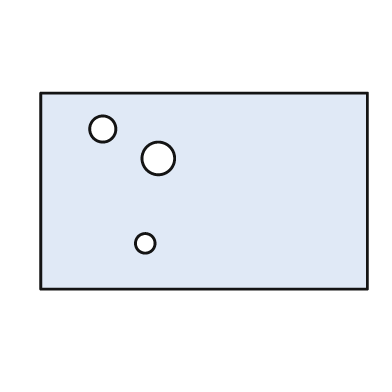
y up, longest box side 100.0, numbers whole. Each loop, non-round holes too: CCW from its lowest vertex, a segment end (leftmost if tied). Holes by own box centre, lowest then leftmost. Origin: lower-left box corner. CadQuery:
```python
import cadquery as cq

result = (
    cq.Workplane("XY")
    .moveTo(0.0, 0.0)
    .lineTo(100.0, 0.0)
    .lineTo(100.0, 60.0)
    .lineTo(0.0, 60.0)
    .close()
    .moveTo(32.0, 14.0)
    .circle(3.0)
    .moveTo(36.0, 40.0)
    .circle(5.0)
    .moveTo(19.0, 49.0)
    .circle(4.0)
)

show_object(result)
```